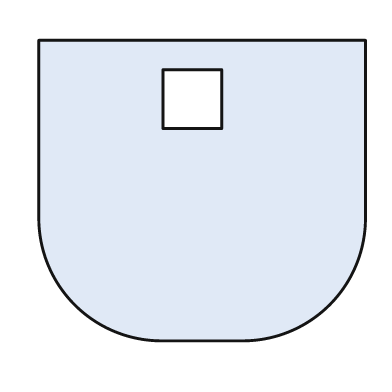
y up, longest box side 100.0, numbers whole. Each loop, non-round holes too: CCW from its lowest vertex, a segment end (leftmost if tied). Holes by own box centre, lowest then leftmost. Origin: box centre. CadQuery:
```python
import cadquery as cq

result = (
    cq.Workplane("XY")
    .moveTo(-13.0, -46.0)
    .lineTo(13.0, -46.0)
    .threePointArc((39.0, -35.0), (50.0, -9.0))
    .lineTo(50.0, 46.0)
    .lineTo(-50.0, 46.0)
    .lineTo(-50.0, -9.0)
    .threePointArc((-39.0, -35.0), (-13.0, -46.0))
    .close()
    .moveTo(-12.0, 19.0)
    .lineTo(6.0, 19.0)
    .lineTo(6.0, 37.0)
    .lineTo(-12.0, 37.0)
    .close()
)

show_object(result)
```